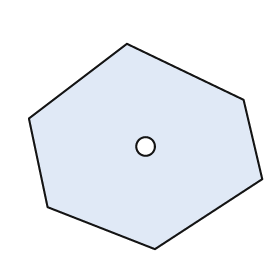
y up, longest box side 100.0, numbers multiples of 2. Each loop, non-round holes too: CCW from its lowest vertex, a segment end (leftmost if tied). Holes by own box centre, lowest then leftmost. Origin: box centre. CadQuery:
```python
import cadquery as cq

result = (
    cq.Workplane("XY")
    .moveTo(4.0, -44.0)
    .lineTo(50.0, -14.0)
    .lineTo(42.0, 20.0)
    .lineTo(-8.0, 44.0)
    .lineTo(-50.0, 12.0)
    .lineTo(-42.0, -26.0)
    .close()
    .moveTo(0.0, 0.0)
    .circle(4.0)
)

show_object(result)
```